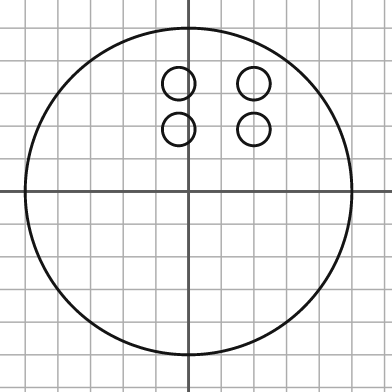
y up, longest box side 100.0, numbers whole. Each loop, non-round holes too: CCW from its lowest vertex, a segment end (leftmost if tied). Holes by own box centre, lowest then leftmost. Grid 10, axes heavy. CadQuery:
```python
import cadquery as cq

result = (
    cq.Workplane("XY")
    .moveTo(0.0, 0.0)
    .circle(50.0)
    .moveTo(-3.0, 19.0)
    .circle(5.0)
    .moveTo(20.0, 19.0)
    .circle(5.0)
    .moveTo(-3.0, 33.0)
    .circle(5.0)
    .moveTo(20.0, 33.0)
    .circle(5.0)
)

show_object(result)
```